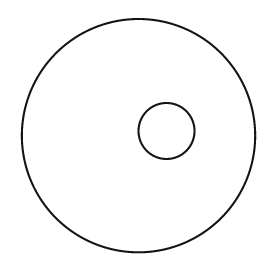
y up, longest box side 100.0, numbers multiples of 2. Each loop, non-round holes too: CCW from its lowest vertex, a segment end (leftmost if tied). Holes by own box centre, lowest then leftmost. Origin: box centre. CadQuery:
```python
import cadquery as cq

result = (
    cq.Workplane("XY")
    .moveTo(0.0, 0.0)
    .circle(50.0)
    .moveTo(12.0, 2.0)
    .circle(12.0)
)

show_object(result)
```